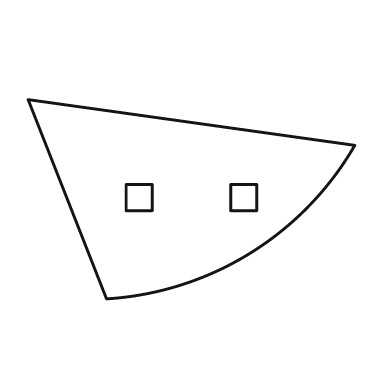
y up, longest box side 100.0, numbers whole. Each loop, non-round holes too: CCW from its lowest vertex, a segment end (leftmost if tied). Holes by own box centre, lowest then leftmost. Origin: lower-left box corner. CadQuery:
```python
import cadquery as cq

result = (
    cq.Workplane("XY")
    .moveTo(24.0, 0.0)
    .threePointArc((68.0, 14.0), (100.0, 47.0))
    .lineTo(0.0, 61.0)
    .close()
    .moveTo(30.0, 27.0)
    .lineTo(38.0, 27.0)
    .lineTo(38.0, 35.0)
    .lineTo(30.0, 35.0)
    .close()
    .moveTo(62.0, 27.0)
    .lineTo(70.0, 27.0)
    .lineTo(70.0, 35.0)
    .lineTo(62.0, 35.0)
    .close()
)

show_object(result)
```